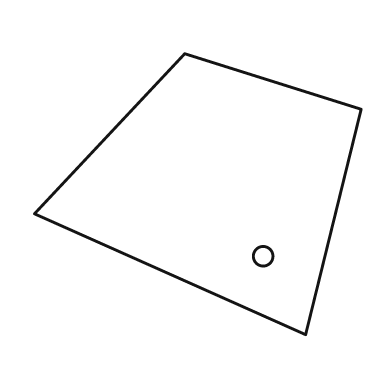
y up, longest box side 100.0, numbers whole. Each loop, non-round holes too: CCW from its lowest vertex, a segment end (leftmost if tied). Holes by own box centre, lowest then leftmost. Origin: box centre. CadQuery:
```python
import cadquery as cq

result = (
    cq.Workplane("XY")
    .moveTo(33.0, -43.0)
    .lineTo(50.0, 26.0)
    .lineTo(-4.0, 43.0)
    .lineTo(-50.0, -6.0)
    .close()
    .moveTo(20.0, -19.0)
    .circle(3.0)
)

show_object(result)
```